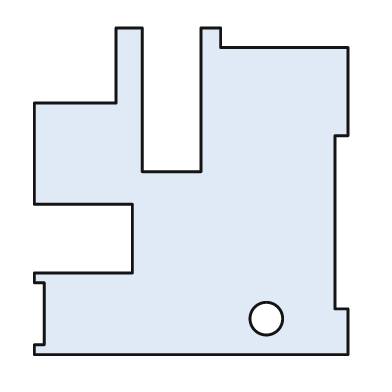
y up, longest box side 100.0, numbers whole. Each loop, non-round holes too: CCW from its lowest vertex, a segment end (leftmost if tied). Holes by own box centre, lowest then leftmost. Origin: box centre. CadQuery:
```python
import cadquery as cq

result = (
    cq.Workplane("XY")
    .moveTo(-48.0, -50.0)
    .lineTo(48.0, -50.0)
    .lineTo(48.0, -36.0)
    .lineTo(44.0, -36.0)
    .lineTo(44.0, 17.0)
    .lineTo(48.0, 17.0)
    .lineTo(48.0, 44.0)
    .lineTo(9.0, 44.0)
    .lineTo(9.0, 50.0)
    .lineTo(3.0, 50.0)
    .lineTo(3.0, 6.0)
    .lineTo(-15.0, 6.0)
    .lineTo(-15.0, 50.0)
    .lineTo(-23.0, 50.0)
    .lineTo(-23.0, 27.0)
    .lineTo(-48.0, 27.0)
    .lineTo(-48.0, -4.0)
    .lineTo(-18.0, -4.0)
    .lineTo(-18.0, -25.0)
    .lineTo(-48.0, -25.0)
    .lineTo(-48.0, -28.0)
    .lineTo(-45.0, -28.0)
    .lineTo(-45.0, -47.0)
    .lineTo(-48.0, -47.0)
    .close()
    .moveTo(23.0, -39.0)
    .circle(5.0)
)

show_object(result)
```